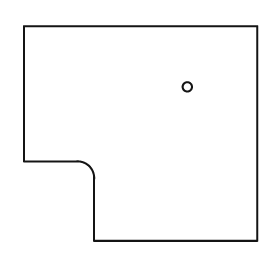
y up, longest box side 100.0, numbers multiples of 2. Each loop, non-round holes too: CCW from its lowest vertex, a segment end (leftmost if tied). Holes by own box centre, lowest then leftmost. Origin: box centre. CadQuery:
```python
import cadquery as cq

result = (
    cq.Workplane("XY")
    .moveTo(-20.0, -46.0)
    .lineTo(50.0, -46.0)
    .lineTo(50.0, 46.0)
    .lineTo(-50.0, 46.0)
    .lineTo(-50.0, -12.0)
    .lineTo(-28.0, -12.0)
    .threePointArc((-22.0, -14.0), (-20.0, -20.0))
    .close()
    .moveTo(20.0, 20.0)
    .circle(2.0)
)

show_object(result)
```